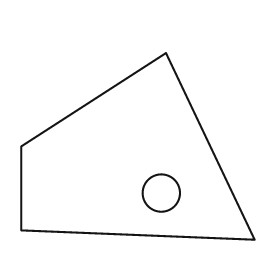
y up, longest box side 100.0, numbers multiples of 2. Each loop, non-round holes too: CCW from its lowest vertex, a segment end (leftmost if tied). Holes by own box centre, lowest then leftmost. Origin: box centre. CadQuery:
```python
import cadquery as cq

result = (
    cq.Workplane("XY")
    .moveTo(50.0, -40.0)
    .lineTo(12.0, 40.0)
    .lineTo(-50.0, 0.0)
    .lineTo(-50.0, -36.0)
    .close()
    .moveTo(10.0, -20.0)
    .circle(8.0)
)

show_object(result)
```